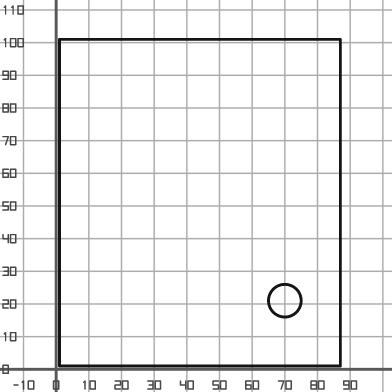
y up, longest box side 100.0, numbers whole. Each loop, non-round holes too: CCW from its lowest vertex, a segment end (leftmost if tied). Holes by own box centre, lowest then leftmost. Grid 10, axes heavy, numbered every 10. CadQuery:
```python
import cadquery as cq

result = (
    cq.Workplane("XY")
    .moveTo(1.0, 1.0)
    .lineTo(87.0, 1.0)
    .lineTo(87.0, 101.0)
    .lineTo(1.0, 101.0)
    .close()
    .moveTo(70.0, 21.0)
    .circle(5.0)
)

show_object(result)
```